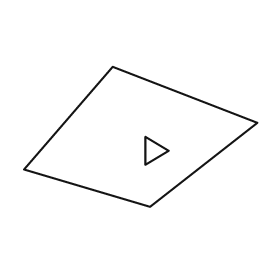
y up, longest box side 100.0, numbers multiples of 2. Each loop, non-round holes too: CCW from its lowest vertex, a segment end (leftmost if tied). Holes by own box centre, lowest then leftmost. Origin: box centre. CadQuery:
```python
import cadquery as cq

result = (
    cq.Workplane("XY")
    .moveTo(4.0, -30.0)
    .lineTo(50.0, 6.0)
    .lineTo(-12.0, 30.0)
    .lineTo(-50.0, -14.0)
    .close()
    .moveTo(2.0, -12.0)
    .lineTo(12.0, -6.0)
    .lineTo(2.0, 0.0)
    .close()
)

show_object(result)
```